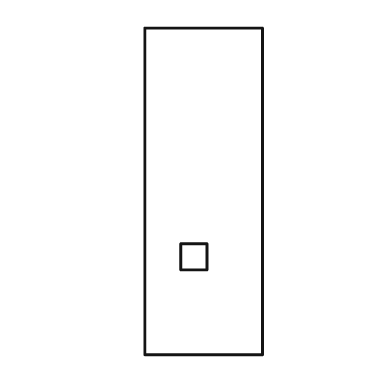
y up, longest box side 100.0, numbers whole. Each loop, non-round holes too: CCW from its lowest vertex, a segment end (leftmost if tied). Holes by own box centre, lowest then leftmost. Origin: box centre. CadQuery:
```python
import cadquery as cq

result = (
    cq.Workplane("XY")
    .moveTo(-18.0, -50.0)
    .lineTo(18.0, -50.0)
    .lineTo(18.0, 50.0)
    .lineTo(-18.0, 50.0)
    .close()
    .moveTo(-7.0, -24.0)
    .lineTo(1.0, -24.0)
    .lineTo(1.0, -16.0)
    .lineTo(-7.0, -16.0)
    .close()
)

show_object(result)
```